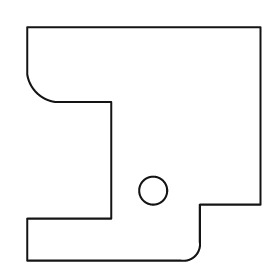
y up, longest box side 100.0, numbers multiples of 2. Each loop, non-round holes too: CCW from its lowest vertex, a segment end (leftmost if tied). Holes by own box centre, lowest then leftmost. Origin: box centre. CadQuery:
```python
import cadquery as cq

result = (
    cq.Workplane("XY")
    .moveTo(-50.0, -50.0)
    .lineTo(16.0, -50.0)
    .threePointArc((22.0, -48.0), (24.0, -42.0))
    .lineTo(24.0, -26.0)
    .lineTo(50.0, -26.0)
    .lineTo(50.0, 50.0)
    .lineTo(-50.0, 50.0)
    .lineTo(-50.0, 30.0)
    .threePointArc((-46.0, 22.0), (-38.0, 18.0))
    .lineTo(-14.0, 18.0)
    .lineTo(-14.0, -32.0)
    .lineTo(-50.0, -32.0)
    .close()
    .moveTo(4.0, -20.0)
    .circle(6.0)
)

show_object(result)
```